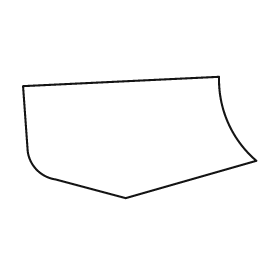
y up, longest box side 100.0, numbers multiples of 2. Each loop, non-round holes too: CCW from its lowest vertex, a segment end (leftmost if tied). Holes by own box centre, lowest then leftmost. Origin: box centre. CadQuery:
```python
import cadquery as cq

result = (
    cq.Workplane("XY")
    .moveTo(-6.0, -26.0)
    .lineTo(50.0, -10.0)
    .threePointArc((38.0, 6.0), (34.0, 26.0))
    .lineTo(-50.0, 22.0)
    .lineTo(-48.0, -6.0)
    .threePointArc((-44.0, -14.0), (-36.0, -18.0))
    .close()
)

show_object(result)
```